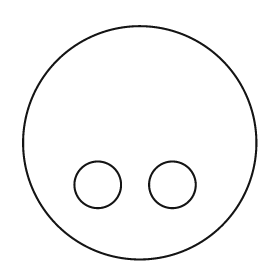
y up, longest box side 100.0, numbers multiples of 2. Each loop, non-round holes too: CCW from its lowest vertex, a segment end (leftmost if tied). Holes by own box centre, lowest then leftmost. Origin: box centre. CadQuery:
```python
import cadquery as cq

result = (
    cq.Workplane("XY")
    .moveTo(0.0, 0.0)
    .circle(50.0)
    .moveTo(-18.0, -18.0)
    .circle(10.0)
    .moveTo(14.0, -18.0)
    .circle(10.0)
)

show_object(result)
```